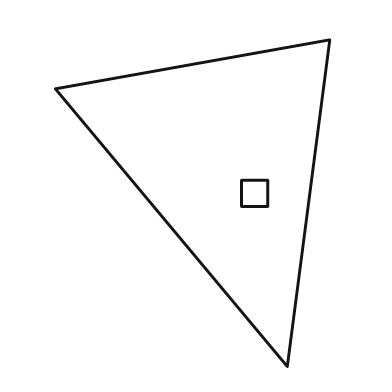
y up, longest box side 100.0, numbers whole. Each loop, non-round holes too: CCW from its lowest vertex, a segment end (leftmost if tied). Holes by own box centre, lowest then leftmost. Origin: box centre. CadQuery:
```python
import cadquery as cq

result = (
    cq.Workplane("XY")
    .moveTo(29.0, -50.0)
    .lineTo(42.0, 50.0)
    .lineTo(-42.0, 35.0)
    .close()
    .moveTo(15.0, -1.0)
    .lineTo(23.0, -1.0)
    .lineTo(23.0, 7.0)
    .lineTo(15.0, 7.0)
    .close()
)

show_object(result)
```